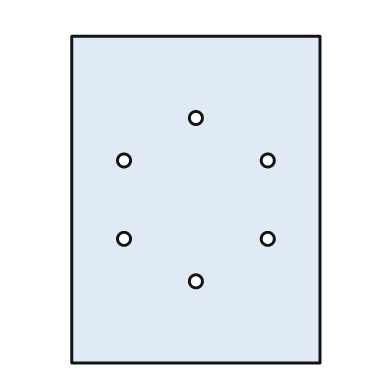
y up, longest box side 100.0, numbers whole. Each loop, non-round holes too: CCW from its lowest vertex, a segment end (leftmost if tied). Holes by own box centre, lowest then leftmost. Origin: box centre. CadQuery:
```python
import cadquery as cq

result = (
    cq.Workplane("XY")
    .moveTo(-38.0, -50.0)
    .lineTo(38.0, -50.0)
    .lineTo(38.0, 50.0)
    .lineTo(-38.0, 50.0)
    .close()
    .moveTo(0.0, -25.0)
    .circle(2.0)
    .moveTo(-22.0, -12.0)
    .circle(2.0)
    .moveTo(22.0, -12.0)
    .circle(2.0)
    .moveTo(-22.0, 12.0)
    .circle(2.0)
    .moveTo(22.0, 12.0)
    .circle(2.0)
    .moveTo(0.0, 25.0)
    .circle(2.0)
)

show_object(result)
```